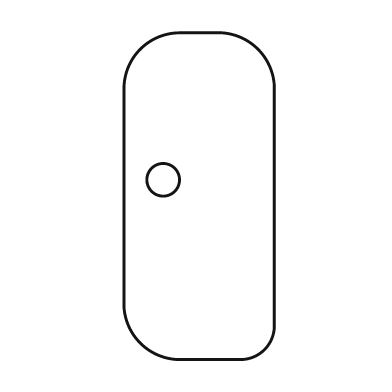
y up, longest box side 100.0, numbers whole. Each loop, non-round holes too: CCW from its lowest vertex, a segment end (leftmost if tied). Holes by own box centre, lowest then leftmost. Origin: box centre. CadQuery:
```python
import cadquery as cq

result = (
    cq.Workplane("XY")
    .moveTo(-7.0, -50.0)
    .lineTo(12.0, -50.0)
    .threePointArc((20.0, -47.0), (23.0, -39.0))
    .lineTo(23.0, 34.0)
    .threePointArc((18.0, 45.0), (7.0, 50.0))
    .lineTo(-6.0, 50.0)
    .threePointArc((-18.0, 45.0), (-23.0, 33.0))
    .lineTo(-23.0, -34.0)
    .threePointArc((-18.0, -45.0), (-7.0, -50.0))
    .close()
    .moveTo(-11.0, 5.0)
    .circle(5.0)
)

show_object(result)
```